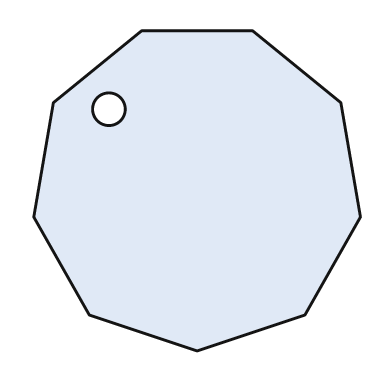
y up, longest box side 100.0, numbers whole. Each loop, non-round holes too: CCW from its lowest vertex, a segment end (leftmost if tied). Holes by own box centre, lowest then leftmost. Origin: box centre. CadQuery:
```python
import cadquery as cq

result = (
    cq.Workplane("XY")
    .moveTo(0.0, -49.0)
    .lineTo(33.0, -38.0)
    .lineTo(50.0, -8.0)
    .lineTo(44.0, 27.0)
    .lineTo(17.0, 49.0)
    .lineTo(-17.0, 49.0)
    .lineTo(-44.0, 27.0)
    .lineTo(-50.0, -8.0)
    .lineTo(-33.0, -38.0)
    .close()
    .moveTo(-27.0, 25.0)
    .circle(5.0)
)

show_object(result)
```